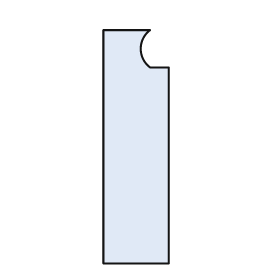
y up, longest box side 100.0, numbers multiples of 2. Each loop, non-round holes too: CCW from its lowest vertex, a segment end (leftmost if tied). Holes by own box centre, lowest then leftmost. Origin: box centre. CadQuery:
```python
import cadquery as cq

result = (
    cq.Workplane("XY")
    .moveTo(-14.0, -50.0)
    .lineTo(14.0, -50.0)
    .lineTo(14.0, 34.0)
    .lineTo(6.0, 34.0)
    .threePointArc((2.0, 42.0), (6.0, 50.0))
    .lineTo(-14.0, 50.0)
    .close()
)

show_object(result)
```